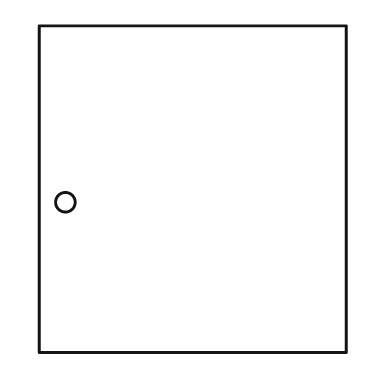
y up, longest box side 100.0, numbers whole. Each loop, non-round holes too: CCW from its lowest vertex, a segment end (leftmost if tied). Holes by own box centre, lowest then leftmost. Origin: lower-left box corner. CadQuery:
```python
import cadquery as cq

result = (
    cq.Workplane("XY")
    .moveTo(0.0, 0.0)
    .lineTo(94.0, 0.0)
    .lineTo(94.0, 100.0)
    .lineTo(0.0, 100.0)
    .close()
    .moveTo(8.0, 46.0)
    .circle(3.0)
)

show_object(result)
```